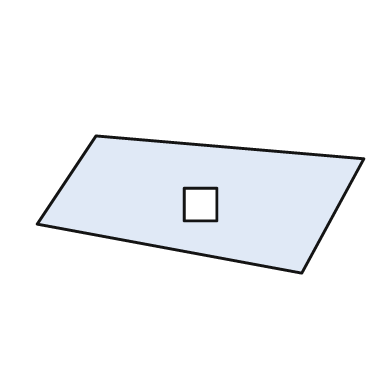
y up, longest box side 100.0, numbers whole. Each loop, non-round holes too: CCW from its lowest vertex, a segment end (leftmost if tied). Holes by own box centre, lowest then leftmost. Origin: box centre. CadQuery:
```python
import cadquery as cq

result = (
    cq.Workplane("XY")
    .moveTo(31.0, -21.0)
    .lineTo(50.0, 14.0)
    .lineTo(-32.0, 21.0)
    .lineTo(-50.0, -6.0)
    .close()
    .moveTo(-5.0, -5.0)
    .lineTo(5.0, -5.0)
    .lineTo(5.0, 5.0)
    .lineTo(-5.0, 5.0)
    .close()
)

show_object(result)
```